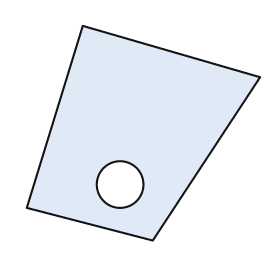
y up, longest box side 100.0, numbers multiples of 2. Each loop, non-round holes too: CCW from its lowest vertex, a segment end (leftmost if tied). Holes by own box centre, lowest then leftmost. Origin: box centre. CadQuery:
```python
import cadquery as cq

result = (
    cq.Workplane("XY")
    .moveTo(4.0, -46.0)
    .lineTo(50.0, 24.0)
    .lineTo(-26.0, 46.0)
    .lineTo(-50.0, -32.0)
    .close()
    .moveTo(-10.0, -22.0)
    .circle(10.0)
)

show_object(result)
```